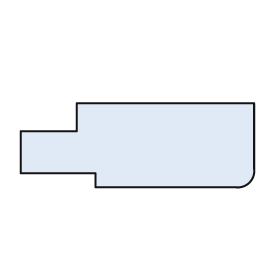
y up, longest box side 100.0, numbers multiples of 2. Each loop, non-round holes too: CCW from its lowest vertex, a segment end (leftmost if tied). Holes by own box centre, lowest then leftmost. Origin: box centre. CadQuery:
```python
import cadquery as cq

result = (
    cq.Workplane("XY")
    .moveTo(-18.0, -18.0)
    .lineTo(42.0, -18.0)
    .threePointArc((48.0, -16.0), (50.0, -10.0))
    .lineTo(50.0, 18.0)
    .lineTo(-26.0, 18.0)
    .lineTo(-26.0, 6.0)
    .lineTo(-50.0, 6.0)
    .lineTo(-50.0, -12.0)
    .lineTo(-18.0, -12.0)
    .close()
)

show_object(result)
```